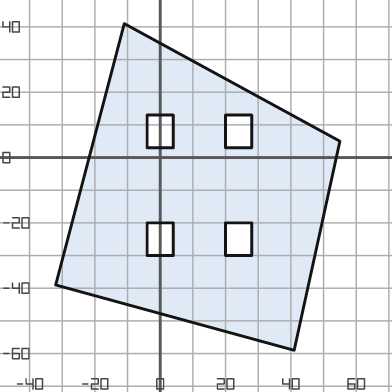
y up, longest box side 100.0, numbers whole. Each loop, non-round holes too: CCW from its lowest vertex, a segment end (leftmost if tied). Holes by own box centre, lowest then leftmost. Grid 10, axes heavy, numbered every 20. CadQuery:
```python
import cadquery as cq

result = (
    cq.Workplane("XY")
    .moveTo(41.0, -59.0)
    .lineTo(55.0, 5.0)
    .lineTo(-11.0, 41.0)
    .lineTo(-32.0, -39.0)
    .close()
    .moveTo(-4.0, -30.0)
    .lineTo(4.0, -30.0)
    .lineTo(4.0, -20.0)
    .lineTo(-4.0, -20.0)
    .close()
    .moveTo(20.0, -30.0)
    .lineTo(28.0, -30.0)
    .lineTo(28.0, -20.0)
    .lineTo(20.0, -20.0)
    .close()
    .moveTo(-4.0, 3.0)
    .lineTo(4.0, 3.0)
    .lineTo(4.0, 13.0)
    .lineTo(-4.0, 13.0)
    .close()
    .moveTo(20.0, 3.0)
    .lineTo(28.0, 3.0)
    .lineTo(28.0, 13.0)
    .lineTo(20.0, 13.0)
    .close()
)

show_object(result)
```